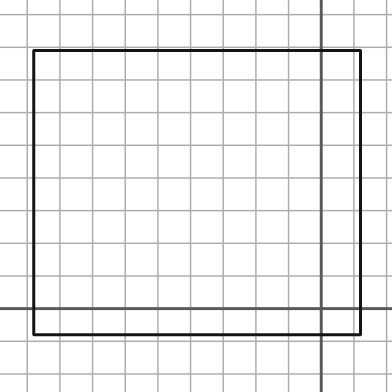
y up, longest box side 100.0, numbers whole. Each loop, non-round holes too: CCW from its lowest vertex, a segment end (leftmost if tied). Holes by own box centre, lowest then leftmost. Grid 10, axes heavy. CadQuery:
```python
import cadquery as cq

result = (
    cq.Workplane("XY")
    .moveTo(-88.0, -8.0)
    .lineTo(12.0, -8.0)
    .lineTo(12.0, 79.0)
    .lineTo(-88.0, 79.0)
    .close()
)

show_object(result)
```